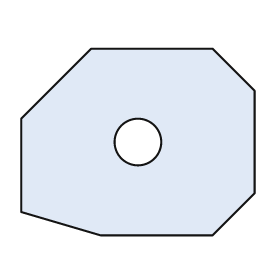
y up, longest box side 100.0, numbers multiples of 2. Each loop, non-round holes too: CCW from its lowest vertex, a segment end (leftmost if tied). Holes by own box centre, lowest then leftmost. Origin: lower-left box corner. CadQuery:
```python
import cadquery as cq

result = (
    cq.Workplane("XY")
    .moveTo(34.0, 0.0)
    .lineTo(82.0, 0.0)
    .lineTo(100.0, 18.0)
    .lineTo(100.0, 62.0)
    .lineTo(82.0, 80.0)
    .lineTo(30.0, 80.0)
    .lineTo(0.0, 50.0)
    .lineTo(0.0, 10.0)
    .close()
    .moveTo(50.0, 40.0)
    .circle(10.0)
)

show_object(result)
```